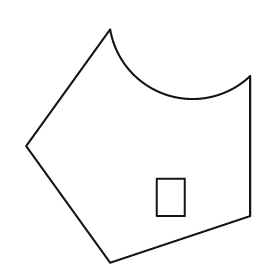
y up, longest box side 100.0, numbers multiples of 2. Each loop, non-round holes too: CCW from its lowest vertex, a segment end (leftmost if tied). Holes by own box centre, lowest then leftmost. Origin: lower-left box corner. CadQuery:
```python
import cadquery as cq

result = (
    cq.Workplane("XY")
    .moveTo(36.0, 0.0)
    .lineTo(96.0, 20.0)
    .lineTo(96.0, 80.0)
    .threePointArc((60.0, 72.0), (36.0, 100.0))
    .lineTo(0.0, 50.0)
    .close()
    .moveTo(56.0, 20.0)
    .lineTo(68.0, 20.0)
    .lineTo(68.0, 36.0)
    .lineTo(56.0, 36.0)
    .close()
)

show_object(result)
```